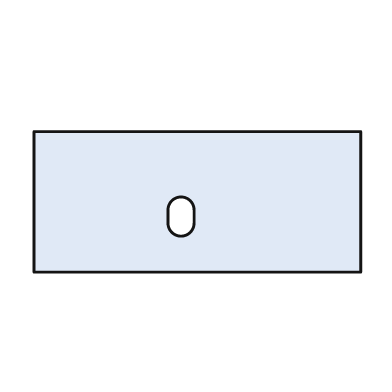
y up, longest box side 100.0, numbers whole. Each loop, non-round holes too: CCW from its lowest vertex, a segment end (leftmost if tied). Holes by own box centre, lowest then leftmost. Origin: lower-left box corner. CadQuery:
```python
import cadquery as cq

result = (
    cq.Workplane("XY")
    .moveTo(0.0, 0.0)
    .lineTo(100.0, 0.0)
    .lineTo(100.0, 43.0)
    .lineTo(0.0, 43.0)
    .close()
    .moveTo(41.0, 15.0)
    .threePointArc((45.0, 11.0), (49.0, 15.0))
    .lineTo(49.0, 19.0)
    .threePointArc((45.0, 23.0), (41.0, 19.0))
    .close()
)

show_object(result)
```